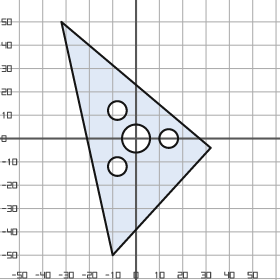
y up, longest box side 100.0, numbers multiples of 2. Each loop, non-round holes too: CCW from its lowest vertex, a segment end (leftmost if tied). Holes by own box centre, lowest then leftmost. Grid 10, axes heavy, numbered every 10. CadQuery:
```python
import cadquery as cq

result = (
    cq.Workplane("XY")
    .moveTo(-10.0, -50.0)
    .lineTo(32.0, -4.0)
    .lineTo(-32.0, 50.0)
    .close()
    .moveTo(-8.0, -12.0)
    .circle(4.0)
    .moveTo(0.0, 0.0)
    .circle(6.0)
    .moveTo(14.0, 0.0)
    .circle(4.0)
    .moveTo(-8.0, 12.0)
    .circle(4.0)
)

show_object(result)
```